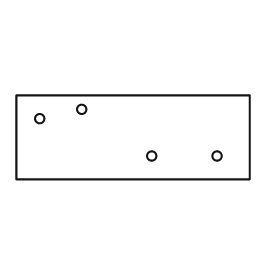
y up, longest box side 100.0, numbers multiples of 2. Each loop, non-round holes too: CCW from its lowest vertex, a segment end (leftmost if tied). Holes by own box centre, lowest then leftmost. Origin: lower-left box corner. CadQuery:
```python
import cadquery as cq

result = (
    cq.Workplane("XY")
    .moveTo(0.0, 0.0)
    .lineTo(100.0, 0.0)
    .lineTo(100.0, 36.0)
    .lineTo(0.0, 36.0)
    .close()
    .moveTo(58.0, 10.0)
    .circle(2.0)
    .moveTo(86.0, 10.0)
    .circle(2.0)
    .moveTo(10.0, 26.0)
    .circle(2.0)
    .moveTo(28.0, 30.0)
    .circle(2.0)
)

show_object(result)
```